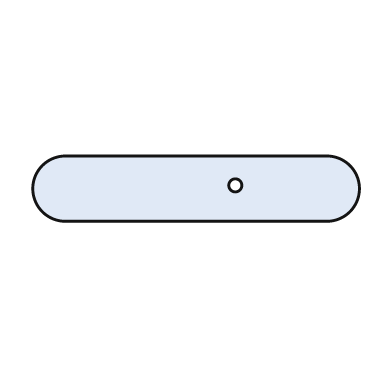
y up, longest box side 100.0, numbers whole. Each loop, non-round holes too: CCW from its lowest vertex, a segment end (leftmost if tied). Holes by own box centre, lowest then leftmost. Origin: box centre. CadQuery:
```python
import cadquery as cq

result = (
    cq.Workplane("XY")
    .moveTo(-40.0, -10.0)
    .lineTo(40.0, -10.0)
    .threePointArc((50.0, 0.0), (40.0, 10.0))
    .lineTo(-40.0, 10.0)
    .threePointArc((-50.0, 0.0), (-40.0, -10.0))
    .close()
    .moveTo(12.0, 1.0)
    .circle(2.0)
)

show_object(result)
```